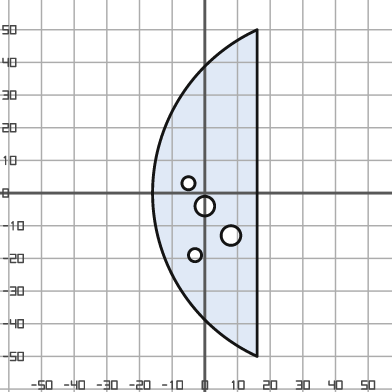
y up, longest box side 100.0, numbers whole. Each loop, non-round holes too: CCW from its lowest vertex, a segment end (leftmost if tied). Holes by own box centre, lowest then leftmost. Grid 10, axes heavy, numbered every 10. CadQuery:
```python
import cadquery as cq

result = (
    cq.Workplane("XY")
    .moveTo(16.0, -50.0)
    .lineTo(16.0, 50.0)
    .threePointArc((-16.0, 0.0), (16.0, -50.0))
    .close()
    .moveTo(-3.0, -19.0)
    .circle(2.0)
    .moveTo(8.0, -13.0)
    .circle(3.0)
    .moveTo(0.0, -4.0)
    .circle(3.0)
    .moveTo(-5.0, 3.0)
    .circle(2.0)
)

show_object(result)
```